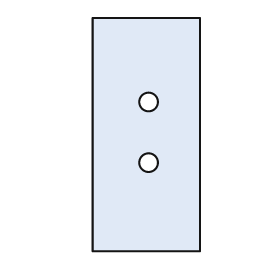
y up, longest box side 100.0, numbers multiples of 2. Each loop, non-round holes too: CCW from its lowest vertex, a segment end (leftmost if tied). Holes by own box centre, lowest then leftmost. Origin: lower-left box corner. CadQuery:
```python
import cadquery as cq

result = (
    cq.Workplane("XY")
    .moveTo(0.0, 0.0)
    .lineTo(46.0, 0.0)
    .lineTo(46.0, 100.0)
    .lineTo(0.0, 100.0)
    .close()
    .moveTo(24.0, 38.0)
    .circle(4.0)
    .moveTo(24.0, 64.0)
    .circle(4.0)
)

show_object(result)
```